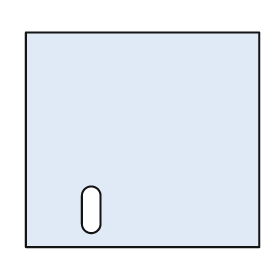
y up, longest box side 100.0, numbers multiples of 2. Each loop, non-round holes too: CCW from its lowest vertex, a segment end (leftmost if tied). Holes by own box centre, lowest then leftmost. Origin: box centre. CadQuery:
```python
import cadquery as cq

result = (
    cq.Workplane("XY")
    .moveTo(-50.0, -46.0)
    .lineTo(50.0, -46.0)
    .lineTo(50.0, 46.0)
    .lineTo(-50.0, 46.0)
    .close()
    .moveTo(-26.0, -36.0)
    .threePointArc((-22.0, -40.0), (-18.0, -36.0))
    .lineTo(-18.0, -24.0)
    .threePointArc((-22.0, -20.0), (-26.0, -24.0))
    .close()
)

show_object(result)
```